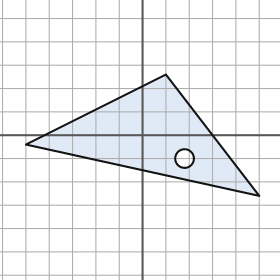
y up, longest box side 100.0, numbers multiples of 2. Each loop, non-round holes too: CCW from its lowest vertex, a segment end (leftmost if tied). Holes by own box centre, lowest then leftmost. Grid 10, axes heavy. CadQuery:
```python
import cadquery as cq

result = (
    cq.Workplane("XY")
    .moveTo(50.0, -26.0)
    .lineTo(10.0, 26.0)
    .lineTo(-50.0, -4.0)
    .close()
    .moveTo(18.0, -10.0)
    .circle(4.0)
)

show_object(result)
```